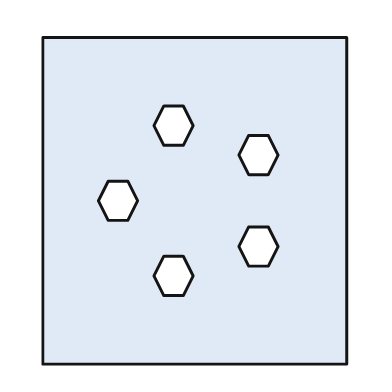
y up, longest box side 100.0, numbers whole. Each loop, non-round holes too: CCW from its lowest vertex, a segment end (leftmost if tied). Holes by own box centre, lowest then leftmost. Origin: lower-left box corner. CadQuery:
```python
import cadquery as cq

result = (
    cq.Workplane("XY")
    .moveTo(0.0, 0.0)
    .lineTo(93.0, 0.0)
    .lineTo(93.0, 100.0)
    .lineTo(0.0, 100.0)
    .close()
    .moveTo(37.0, 21.0)
    .lineTo(43.0, 21.0)
    .lineTo(46.0, 27.0)
    .lineTo(43.0, 33.0)
    .lineTo(37.0, 33.0)
    .lineTo(34.0, 27.0)
    .close()
    .moveTo(63.0, 30.0)
    .lineTo(69.0, 30.0)
    .lineTo(72.0, 36.0)
    .lineTo(69.0, 42.0)
    .lineTo(63.0, 42.0)
    .lineTo(60.0, 36.0)
    .close()
    .moveTo(20.0, 44.0)
    .lineTo(26.0, 44.0)
    .lineTo(29.0, 50.0)
    .lineTo(26.0, 56.0)
    .lineTo(20.0, 56.0)
    .lineTo(17.0, 50.0)
    .close()
    .moveTo(63.0, 58.0)
    .lineTo(69.0, 58.0)
    .lineTo(72.0, 64.0)
    .lineTo(69.0, 70.0)
    .lineTo(63.0, 70.0)
    .lineTo(60.0, 64.0)
    .close()
    .moveTo(37.0, 67.0)
    .lineTo(43.0, 67.0)
    .lineTo(46.0, 73.0)
    .lineTo(43.0, 79.0)
    .lineTo(37.0, 79.0)
    .lineTo(34.0, 73.0)
    .close()
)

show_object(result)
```